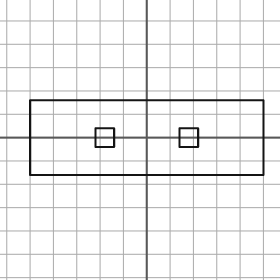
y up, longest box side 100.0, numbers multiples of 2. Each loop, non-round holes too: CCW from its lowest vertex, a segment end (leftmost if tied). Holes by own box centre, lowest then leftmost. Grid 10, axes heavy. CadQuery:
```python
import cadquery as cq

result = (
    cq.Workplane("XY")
    .moveTo(-50.0, -16.0)
    .lineTo(50.0, -16.0)
    .lineTo(50.0, 16.0)
    .lineTo(-50.0, 16.0)
    .close()
    .moveTo(-22.0, -4.0)
    .lineTo(-14.0, -4.0)
    .lineTo(-14.0, 4.0)
    .lineTo(-22.0, 4.0)
    .close()
    .moveTo(14.0, -4.0)
    .lineTo(22.0, -4.0)
    .lineTo(22.0, 4.0)
    .lineTo(14.0, 4.0)
    .close()
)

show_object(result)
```